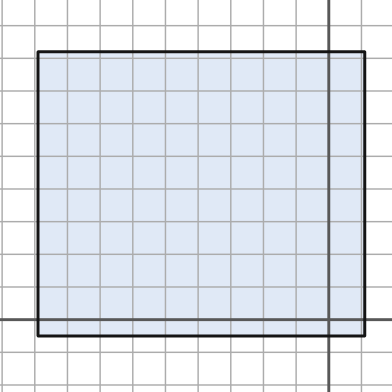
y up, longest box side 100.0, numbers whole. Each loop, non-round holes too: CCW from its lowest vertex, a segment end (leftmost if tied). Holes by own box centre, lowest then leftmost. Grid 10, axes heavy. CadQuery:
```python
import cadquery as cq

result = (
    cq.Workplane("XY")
    .moveTo(-89.0, -5.0)
    .lineTo(11.0, -5.0)
    .lineTo(11.0, 82.0)
    .lineTo(-89.0, 82.0)
    .close()
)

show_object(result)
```